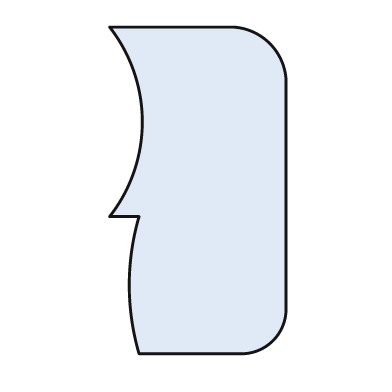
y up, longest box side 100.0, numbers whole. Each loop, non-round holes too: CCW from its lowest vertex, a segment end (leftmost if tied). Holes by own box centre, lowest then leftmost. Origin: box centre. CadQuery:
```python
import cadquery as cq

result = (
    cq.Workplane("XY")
    .moveTo(-18.0, -50.0)
    .lineTo(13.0, -50.0)
    .threePointArc((23.0, -46.0), (27.0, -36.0))
    .lineTo(27.0, 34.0)
    .threePointArc((22.0, 45.0), (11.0, 50.0))
    .lineTo(-27.0, 50.0)
    .threePointArc((-17.0, 21.0), (-27.0, -8.0))
    .lineTo(-18.0, -8.0)
    .threePointArc((-21.0, -29.0), (-18.0, -50.0))
    .close()
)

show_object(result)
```